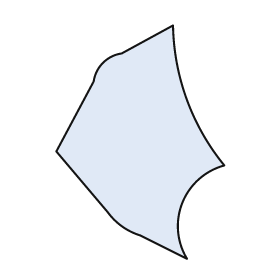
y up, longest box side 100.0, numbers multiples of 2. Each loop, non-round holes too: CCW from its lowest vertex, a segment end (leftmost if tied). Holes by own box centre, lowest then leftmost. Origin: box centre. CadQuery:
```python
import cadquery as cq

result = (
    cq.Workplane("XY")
    .moveTo(20.0, -50.0)
    .threePointArc((18.0, -26.0), (36.0, -10.0))
    .threePointArc((20.0, 18.0), (14.0, 50.0))
    .lineTo(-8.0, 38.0)
    .threePointArc((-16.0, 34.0), (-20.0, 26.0))
    .lineTo(-36.0, -4.0)
    .lineTo(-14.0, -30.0)
    .threePointArc((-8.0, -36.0), (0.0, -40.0))
    .close()
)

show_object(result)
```